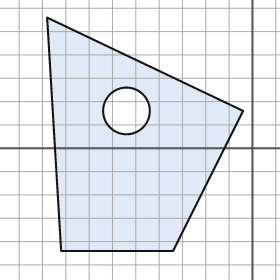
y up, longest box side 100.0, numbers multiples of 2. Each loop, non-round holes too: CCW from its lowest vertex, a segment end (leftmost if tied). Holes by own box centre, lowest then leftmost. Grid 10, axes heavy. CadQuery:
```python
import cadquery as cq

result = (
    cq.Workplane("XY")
    .moveTo(-82.0, -44.0)
    .lineTo(-34.0, -44.0)
    .lineTo(-4.0, 16.0)
    .lineTo(-88.0, 56.0)
    .close()
    .moveTo(-54.0, 16.0)
    .circle(10.0)
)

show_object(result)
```